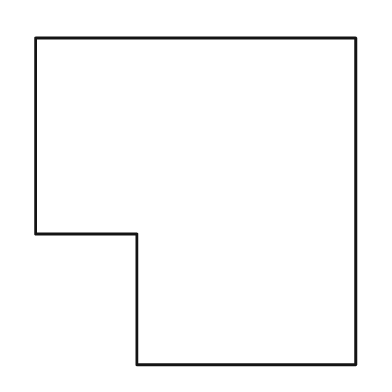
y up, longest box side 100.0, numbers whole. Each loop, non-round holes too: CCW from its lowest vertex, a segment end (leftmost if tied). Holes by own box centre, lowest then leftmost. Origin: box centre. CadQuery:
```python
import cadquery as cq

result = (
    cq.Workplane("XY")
    .moveTo(-18.0, -50.0)
    .lineTo(49.0, -50.0)
    .lineTo(49.0, 50.0)
    .lineTo(-49.0, 50.0)
    .lineTo(-49.0, -10.0)
    .lineTo(-18.0, -10.0)
    .close()
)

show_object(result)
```